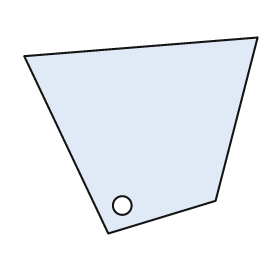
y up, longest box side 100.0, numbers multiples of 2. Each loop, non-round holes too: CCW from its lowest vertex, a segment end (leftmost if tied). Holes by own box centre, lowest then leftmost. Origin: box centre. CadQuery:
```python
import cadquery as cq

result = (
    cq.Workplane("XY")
    .moveTo(-14.0, -42.0)
    .lineTo(32.0, -28.0)
    .lineTo(50.0, 42.0)
    .lineTo(-50.0, 34.0)
    .close()
    .moveTo(-8.0, -30.0)
    .circle(4.0)
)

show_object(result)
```